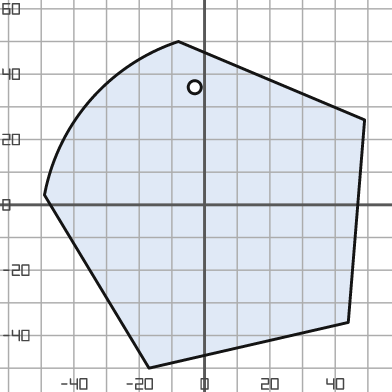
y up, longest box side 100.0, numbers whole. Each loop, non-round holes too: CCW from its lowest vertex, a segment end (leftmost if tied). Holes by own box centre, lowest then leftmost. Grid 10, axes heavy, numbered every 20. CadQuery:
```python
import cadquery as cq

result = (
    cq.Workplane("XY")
    .moveTo(-17.0, -50.0)
    .lineTo(44.0, -36.0)
    .lineTo(49.0, 26.0)
    .lineTo(-8.0, 50.0)
    .threePointArc((-35.0, 32.0), (-49.0, 3.0))
    .close()
    .moveTo(-3.0, 36.0)
    .circle(2.0)
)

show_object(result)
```